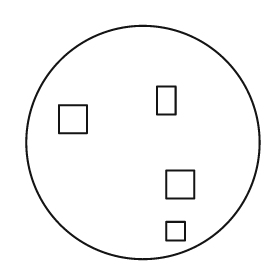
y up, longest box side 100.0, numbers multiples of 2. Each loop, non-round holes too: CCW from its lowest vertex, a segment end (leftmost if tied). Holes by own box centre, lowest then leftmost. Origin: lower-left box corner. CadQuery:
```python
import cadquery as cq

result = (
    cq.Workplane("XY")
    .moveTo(50.0, 50.0)
    .circle(50.0)
    .moveTo(60.0, 8.0)
    .lineTo(68.0, 8.0)
    .lineTo(68.0, 16.0)
    .lineTo(60.0, 16.0)
    .close()
    .moveTo(60.0, 26.0)
    .lineTo(72.0, 26.0)
    .lineTo(72.0, 38.0)
    .lineTo(60.0, 38.0)
    .close()
    .moveTo(14.0, 54.0)
    .lineTo(26.0, 54.0)
    .lineTo(26.0, 66.0)
    .lineTo(14.0, 66.0)
    .close()
    .moveTo(56.0, 62.0)
    .lineTo(64.0, 62.0)
    .lineTo(64.0, 74.0)
    .lineTo(56.0, 74.0)
    .close()
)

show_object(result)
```